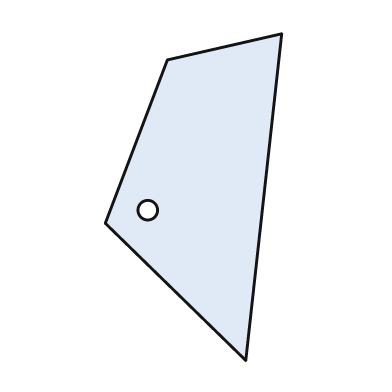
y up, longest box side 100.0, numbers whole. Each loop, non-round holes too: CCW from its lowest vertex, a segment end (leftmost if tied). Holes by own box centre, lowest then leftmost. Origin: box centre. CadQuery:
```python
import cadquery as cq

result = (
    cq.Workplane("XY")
    .moveTo(16.0, -50.0)
    .lineTo(27.0, 50.0)
    .lineTo(-8.0, 42.0)
    .lineTo(-27.0, -8.0)
    .close()
    .moveTo(-14.0, -4.0)
    .circle(3.0)
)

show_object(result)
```